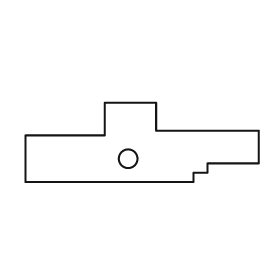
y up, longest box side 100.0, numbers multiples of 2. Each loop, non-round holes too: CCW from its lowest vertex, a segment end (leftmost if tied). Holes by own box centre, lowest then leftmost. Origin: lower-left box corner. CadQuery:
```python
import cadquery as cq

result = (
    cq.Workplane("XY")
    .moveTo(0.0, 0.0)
    .lineTo(72.0, 0.0)
    .lineTo(72.0, 4.0)
    .lineTo(78.0, 4.0)
    .lineTo(78.0, 8.0)
    .lineTo(100.0, 8.0)
    .lineTo(100.0, 22.0)
    .lineTo(56.0, 22.0)
    .lineTo(56.0, 34.0)
    .lineTo(34.0, 34.0)
    .lineTo(34.0, 20.0)
    .lineTo(0.0, 20.0)
    .close()
    .moveTo(44.0, 10.0)
    .circle(4.0)
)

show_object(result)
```